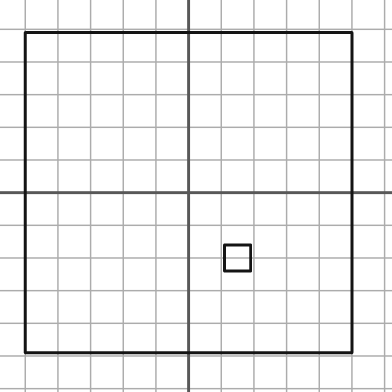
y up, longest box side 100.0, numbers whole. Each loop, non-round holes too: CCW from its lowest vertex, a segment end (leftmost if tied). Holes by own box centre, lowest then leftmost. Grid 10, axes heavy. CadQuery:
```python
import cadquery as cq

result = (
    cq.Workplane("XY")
    .moveTo(-50.0, -49.0)
    .lineTo(50.0, -49.0)
    .lineTo(50.0, 49.0)
    .lineTo(-50.0, 49.0)
    .close()
    .moveTo(11.0, -24.0)
    .lineTo(19.0, -24.0)
    .lineTo(19.0, -16.0)
    .lineTo(11.0, -16.0)
    .close()
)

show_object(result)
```